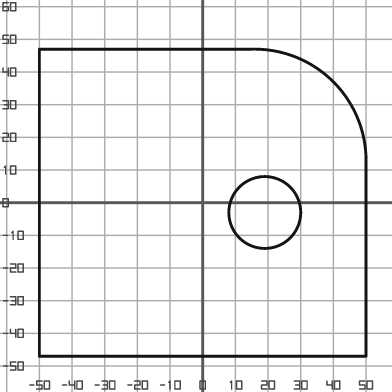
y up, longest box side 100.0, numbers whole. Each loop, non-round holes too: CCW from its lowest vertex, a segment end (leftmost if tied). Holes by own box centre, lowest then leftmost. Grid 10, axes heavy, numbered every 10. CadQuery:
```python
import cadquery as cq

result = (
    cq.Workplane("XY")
    .moveTo(-50.0, -47.0)
    .lineTo(50.0, -47.0)
    .lineTo(50.0, 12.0)
    .threePointArc((40.0, 37.0), (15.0, 47.0))
    .lineTo(-50.0, 47.0)
    .close()
    .moveTo(19.0, -3.0)
    .circle(11.0)
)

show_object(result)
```